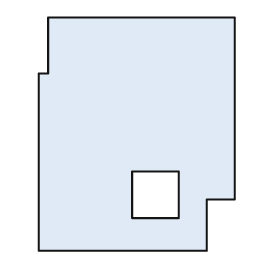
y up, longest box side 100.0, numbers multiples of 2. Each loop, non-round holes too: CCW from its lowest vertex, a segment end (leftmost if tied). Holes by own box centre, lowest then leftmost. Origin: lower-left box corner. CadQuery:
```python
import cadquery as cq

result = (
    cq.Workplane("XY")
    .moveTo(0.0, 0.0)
    .lineTo(72.0, 0.0)
    .lineTo(72.0, 22.0)
    .lineTo(84.0, 22.0)
    .lineTo(84.0, 100.0)
    .lineTo(4.0, 100.0)
    .lineTo(4.0, 76.0)
    .lineTo(0.0, 76.0)
    .close()
    .moveTo(40.0, 14.0)
    .lineTo(60.0, 14.0)
    .lineTo(60.0, 34.0)
    .lineTo(40.0, 34.0)
    .close()
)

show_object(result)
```